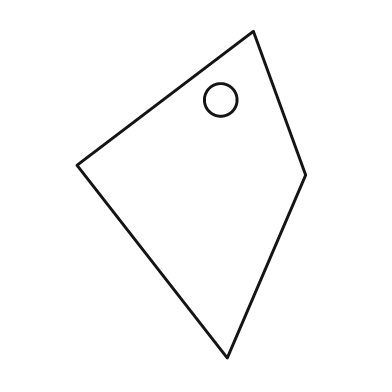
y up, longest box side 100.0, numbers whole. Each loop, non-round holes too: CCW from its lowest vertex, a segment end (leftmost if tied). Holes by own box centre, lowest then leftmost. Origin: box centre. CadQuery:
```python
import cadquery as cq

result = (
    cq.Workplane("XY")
    .moveTo(11.0, -50.0)
    .lineTo(35.0, 6.0)
    .lineTo(19.0, 50.0)
    .lineTo(-35.0, 9.0)
    .close()
    .moveTo(9.0, 29.0)
    .circle(5.0)
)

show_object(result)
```